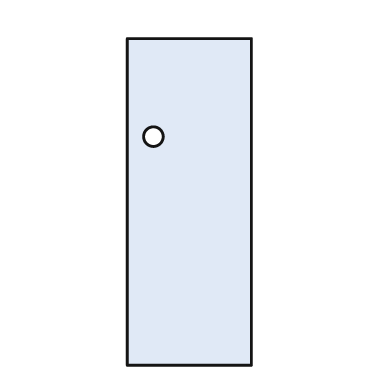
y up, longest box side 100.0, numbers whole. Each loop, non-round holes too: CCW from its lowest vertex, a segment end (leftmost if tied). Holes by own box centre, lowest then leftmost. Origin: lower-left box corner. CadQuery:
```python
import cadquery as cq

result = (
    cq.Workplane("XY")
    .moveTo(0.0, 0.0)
    .lineTo(38.0, 0.0)
    .lineTo(38.0, 100.0)
    .lineTo(0.0, 100.0)
    .close()
    .moveTo(8.0, 70.0)
    .circle(3.0)
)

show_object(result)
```